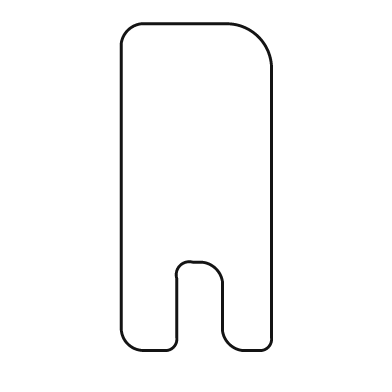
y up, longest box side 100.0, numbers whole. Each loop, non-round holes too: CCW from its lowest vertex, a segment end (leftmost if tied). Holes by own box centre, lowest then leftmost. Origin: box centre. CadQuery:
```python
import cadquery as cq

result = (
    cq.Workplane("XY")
    .moveTo(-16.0, -50.0)
    .lineTo(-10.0, -50.0)
    .threePointArc((-7.0, -49.0), (-6.0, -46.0))
    .lineTo(-6.0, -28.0)
    .threePointArc((-5.0, -24.0), (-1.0, -23.0))
    .lineTo(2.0, -23.0)
    .threePointArc((6.0, -25.0), (8.0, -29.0))
    .lineTo(8.0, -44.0)
    .threePointArc((10.0, -48.0), (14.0, -50.0))
    .lineTo(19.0, -50.0)
    .threePointArc((22.0, -49.0), (23.0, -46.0))
    .lineTo(23.0, 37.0)
    .threePointArc((19.0, 46.0), (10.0, 50.0))
    .lineTo(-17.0, 50.0)
    .threePointArc((-21.0, 48.0), (-23.0, 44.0))
    .lineTo(-23.0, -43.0)
    .threePointArc((-21.0, -48.0), (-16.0, -50.0))
    .close()
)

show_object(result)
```